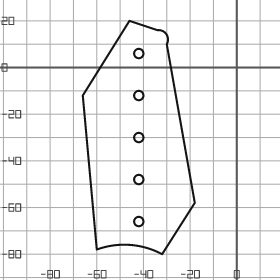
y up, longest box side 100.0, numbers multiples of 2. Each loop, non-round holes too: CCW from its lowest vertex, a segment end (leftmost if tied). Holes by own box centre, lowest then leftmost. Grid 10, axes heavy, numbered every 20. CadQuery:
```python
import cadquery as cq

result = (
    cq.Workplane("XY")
    .moveTo(-32.0, -80.0)
    .lineTo(-18.0, -58.0)
    .lineTo(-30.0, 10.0)
    .threePointArc((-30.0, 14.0), (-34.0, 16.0))
    .lineTo(-46.0, 20.0)
    .lineTo(-66.0, -12.0)
    .lineTo(-60.0, -78.0)
    .threePointArc((-46.0, -76.0), (-32.0, -80.0))
    .close()
    .moveTo(-42.0, -66.0)
    .circle(2.0)
    .moveTo(-42.0, -48.0)
    .circle(2.0)
    .moveTo(-42.0, -30.0)
    .circle(2.0)
    .moveTo(-42.0, -12.0)
    .circle(2.0)
    .moveTo(-42.0, 6.0)
    .circle(2.0)
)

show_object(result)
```